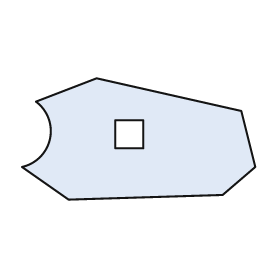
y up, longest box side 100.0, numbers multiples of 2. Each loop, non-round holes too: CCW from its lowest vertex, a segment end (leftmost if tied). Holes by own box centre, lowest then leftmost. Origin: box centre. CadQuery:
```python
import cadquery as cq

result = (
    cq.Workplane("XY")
    .moveTo(-30.0, -26.0)
    .lineTo(36.0, -24.0)
    .lineTo(50.0, -12.0)
    .lineTo(44.0, 12.0)
    .lineTo(-18.0, 26.0)
    .lineTo(-44.0, 16.0)
    .threePointArc((-38.0, 0.0), (-50.0, -12.0))
    .close()
    .moveTo(-10.0, -4.0)
    .lineTo(2.0, -4.0)
    .lineTo(2.0, 8.0)
    .lineTo(-10.0, 8.0)
    .close()
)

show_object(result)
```